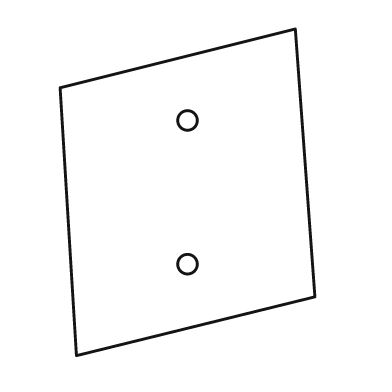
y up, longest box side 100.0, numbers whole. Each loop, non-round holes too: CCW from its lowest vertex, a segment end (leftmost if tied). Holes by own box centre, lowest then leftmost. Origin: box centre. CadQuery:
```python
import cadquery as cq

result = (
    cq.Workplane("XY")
    .moveTo(-34.0, -50.0)
    .lineTo(39.0, -32.0)
    .lineTo(33.0, 50.0)
    .lineTo(-39.0, 32.0)
    .close()
    .moveTo(0.0, -22.0)
    .circle(3.0)
    .moveTo(0.0, 22.0)
    .circle(3.0)
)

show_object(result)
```